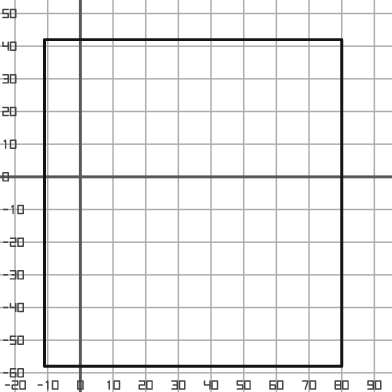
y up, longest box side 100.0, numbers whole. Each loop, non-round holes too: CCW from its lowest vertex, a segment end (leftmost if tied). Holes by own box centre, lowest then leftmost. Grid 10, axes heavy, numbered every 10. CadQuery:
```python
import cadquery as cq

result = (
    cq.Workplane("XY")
    .moveTo(-11.0, -58.0)
    .lineTo(80.0, -58.0)
    .lineTo(80.0, 42.0)
    .lineTo(-11.0, 42.0)
    .close()
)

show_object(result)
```